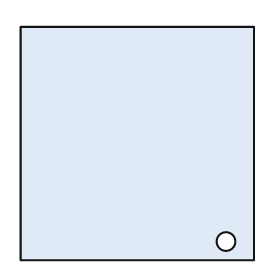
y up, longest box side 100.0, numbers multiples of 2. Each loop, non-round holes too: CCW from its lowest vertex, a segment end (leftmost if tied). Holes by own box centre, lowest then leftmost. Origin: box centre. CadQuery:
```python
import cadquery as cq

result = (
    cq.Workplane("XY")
    .moveTo(-50.0, -50.0)
    .lineTo(50.0, -50.0)
    .lineTo(50.0, 50.0)
    .lineTo(-50.0, 50.0)
    .close()
    .moveTo(38.0, -42.0)
    .circle(4.0)
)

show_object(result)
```